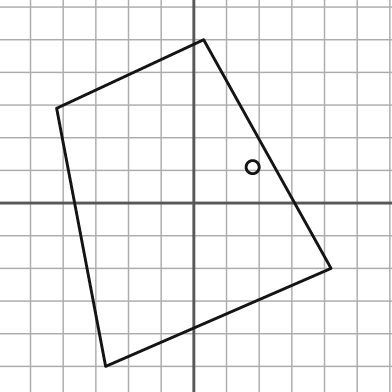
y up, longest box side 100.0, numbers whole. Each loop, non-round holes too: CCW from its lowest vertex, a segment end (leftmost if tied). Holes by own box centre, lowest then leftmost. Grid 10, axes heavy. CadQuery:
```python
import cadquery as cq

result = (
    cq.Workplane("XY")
    .moveTo(-27.0, -50.0)
    .lineTo(42.0, -20.0)
    .lineTo(3.0, 50.0)
    .lineTo(-42.0, 29.0)
    .close()
    .moveTo(18.0, 11.0)
    .circle(2.0)
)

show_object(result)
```